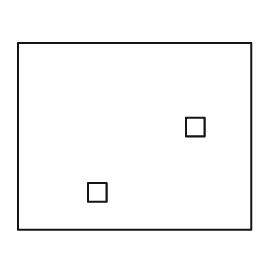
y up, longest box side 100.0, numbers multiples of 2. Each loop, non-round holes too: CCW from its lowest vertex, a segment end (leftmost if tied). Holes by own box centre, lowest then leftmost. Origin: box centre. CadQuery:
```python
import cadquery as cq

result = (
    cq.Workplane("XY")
    .moveTo(-50.0, -40.0)
    .lineTo(50.0, -40.0)
    .lineTo(50.0, 40.0)
    .lineTo(-50.0, 40.0)
    .close()
    .moveTo(-20.0, -28.0)
    .lineTo(-12.0, -28.0)
    .lineTo(-12.0, -20.0)
    .lineTo(-20.0, -20.0)
    .close()
    .moveTo(22.0, 0.0)
    .lineTo(30.0, 0.0)
    .lineTo(30.0, 8.0)
    .lineTo(22.0, 8.0)
    .close()
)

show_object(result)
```